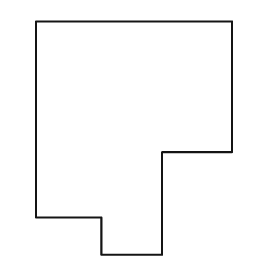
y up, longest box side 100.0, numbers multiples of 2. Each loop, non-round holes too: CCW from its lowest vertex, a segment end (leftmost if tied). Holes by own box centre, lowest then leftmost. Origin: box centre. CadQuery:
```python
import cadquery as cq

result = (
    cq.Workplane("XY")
    .moveTo(-14.0, -50.0)
    .lineTo(12.0, -50.0)
    .lineTo(12.0, -6.0)
    .lineTo(42.0, -6.0)
    .lineTo(42.0, 50.0)
    .lineTo(-42.0, 50.0)
    .lineTo(-42.0, -34.0)
    .lineTo(-14.0, -34.0)
    .close()
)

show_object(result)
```